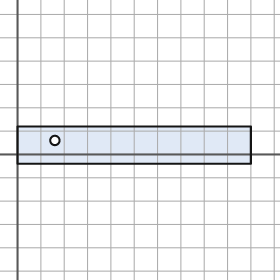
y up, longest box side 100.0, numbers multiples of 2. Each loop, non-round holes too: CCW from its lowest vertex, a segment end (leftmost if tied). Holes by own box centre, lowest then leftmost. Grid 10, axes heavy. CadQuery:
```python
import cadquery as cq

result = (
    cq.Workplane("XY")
    .moveTo(0.0, -4.0)
    .lineTo(100.0, -4.0)
    .lineTo(100.0, 12.0)
    .lineTo(0.0, 12.0)
    .close()
    .moveTo(16.0, 6.0)
    .circle(2.0)
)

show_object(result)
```